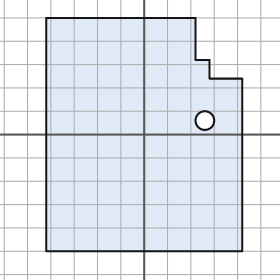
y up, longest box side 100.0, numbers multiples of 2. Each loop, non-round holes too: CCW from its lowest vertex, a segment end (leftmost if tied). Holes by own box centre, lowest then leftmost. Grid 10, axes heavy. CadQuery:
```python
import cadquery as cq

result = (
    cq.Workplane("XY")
    .moveTo(-42.0, -50.0)
    .lineTo(42.0, -50.0)
    .lineTo(42.0, 24.0)
    .lineTo(28.0, 24.0)
    .lineTo(28.0, 32.0)
    .lineTo(22.0, 32.0)
    .lineTo(22.0, 50.0)
    .lineTo(-42.0, 50.0)
    .close()
    .moveTo(26.0, 6.0)
    .circle(4.0)
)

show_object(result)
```